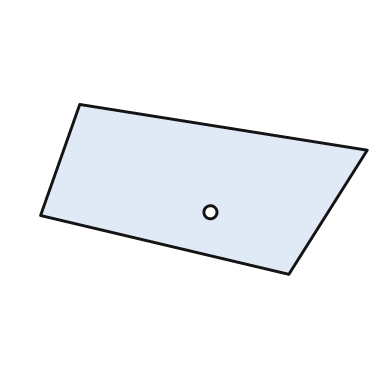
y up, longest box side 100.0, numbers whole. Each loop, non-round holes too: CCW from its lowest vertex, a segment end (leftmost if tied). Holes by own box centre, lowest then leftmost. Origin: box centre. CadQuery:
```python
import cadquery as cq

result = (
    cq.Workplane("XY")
    .moveTo(26.0, -26.0)
    .lineTo(50.0, 12.0)
    .lineTo(-38.0, 26.0)
    .lineTo(-50.0, -8.0)
    .close()
    .moveTo(2.0, -7.0)
    .circle(2.0)
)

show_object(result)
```